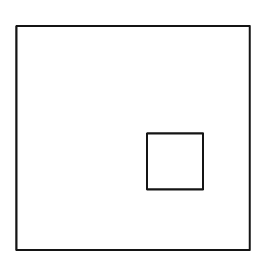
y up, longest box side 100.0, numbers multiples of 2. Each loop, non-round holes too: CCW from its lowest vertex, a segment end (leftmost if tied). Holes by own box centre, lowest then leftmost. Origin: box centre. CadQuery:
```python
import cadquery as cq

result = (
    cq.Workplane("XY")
    .moveTo(-50.0, -48.0)
    .lineTo(50.0, -48.0)
    .lineTo(50.0, 48.0)
    .lineTo(-50.0, 48.0)
    .close()
    .moveTo(6.0, -22.0)
    .lineTo(30.0, -22.0)
    .lineTo(30.0, 2.0)
    .lineTo(6.0, 2.0)
    .close()
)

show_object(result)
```